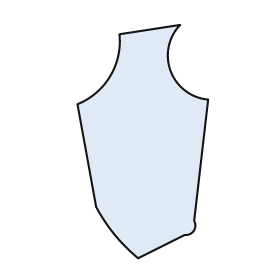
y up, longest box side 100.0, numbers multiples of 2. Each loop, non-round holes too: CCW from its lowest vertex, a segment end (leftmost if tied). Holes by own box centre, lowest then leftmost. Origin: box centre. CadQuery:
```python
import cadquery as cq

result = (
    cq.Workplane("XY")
    .moveTo(-2.0, -50.0)
    .lineTo(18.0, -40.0)
    .threePointArc((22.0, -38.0), (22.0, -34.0))
    .lineTo(28.0, 18.0)
    .threePointArc((12.0, 30.0), (16.0, 50.0))
    .lineTo(-10.0, 46.0)
    .threePointArc((-14.0, 28.0), (-28.0, 16.0))
    .lineTo(-20.0, -28.0)
    .threePointArc((-12.0, -40.0), (-2.0, -50.0))
    .close()
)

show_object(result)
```